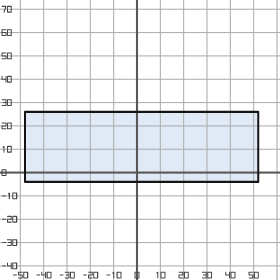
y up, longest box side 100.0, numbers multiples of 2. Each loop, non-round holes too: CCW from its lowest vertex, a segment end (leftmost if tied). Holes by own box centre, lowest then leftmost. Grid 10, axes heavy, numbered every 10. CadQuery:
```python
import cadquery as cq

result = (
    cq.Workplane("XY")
    .moveTo(-48.0, -4.0)
    .lineTo(52.0, -4.0)
    .lineTo(52.0, 26.0)
    .lineTo(-48.0, 26.0)
    .close()
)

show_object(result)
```